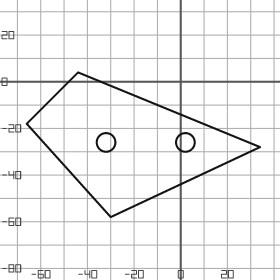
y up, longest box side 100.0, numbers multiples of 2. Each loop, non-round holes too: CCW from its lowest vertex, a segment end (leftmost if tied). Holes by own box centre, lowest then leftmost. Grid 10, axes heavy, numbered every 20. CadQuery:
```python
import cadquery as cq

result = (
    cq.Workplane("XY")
    .moveTo(-30.0, -58.0)
    .lineTo(34.0, -28.0)
    .lineTo(-44.0, 4.0)
    .lineTo(-66.0, -18.0)
    .close()
    .moveTo(-32.0, -26.0)
    .circle(4.0)
    .moveTo(2.0, -26.0)
    .circle(4.0)
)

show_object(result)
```